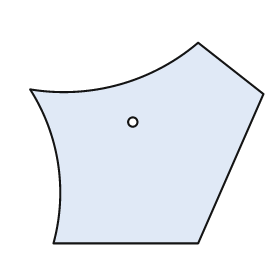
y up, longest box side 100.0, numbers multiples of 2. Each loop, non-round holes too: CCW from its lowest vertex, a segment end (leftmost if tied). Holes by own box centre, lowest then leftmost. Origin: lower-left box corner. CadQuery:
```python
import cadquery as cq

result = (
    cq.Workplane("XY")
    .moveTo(10.0, 0.0)
    .lineTo(72.0, 0.0)
    .lineTo(100.0, 64.0)
    .lineTo(72.0, 86.0)
    .threePointArc((38.0, 68.0), (0.0, 66.0))
    .threePointArc((12.0, 34.0), (10.0, 0.0))
    .close()
    .moveTo(44.0, 52.0)
    .circle(2.0)
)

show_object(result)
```